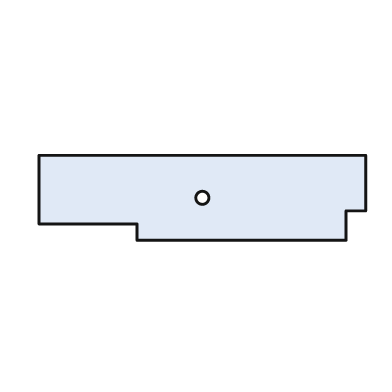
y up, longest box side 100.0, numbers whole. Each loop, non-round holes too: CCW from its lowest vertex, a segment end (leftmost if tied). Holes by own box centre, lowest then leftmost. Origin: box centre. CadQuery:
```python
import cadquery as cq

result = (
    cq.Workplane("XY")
    .moveTo(-20.0, -13.0)
    .lineTo(44.0, -13.0)
    .lineTo(44.0, -4.0)
    .lineTo(50.0, -4.0)
    .lineTo(50.0, 13.0)
    .lineTo(-50.0, 13.0)
    .lineTo(-50.0, -8.0)
    .lineTo(-20.0, -8.0)
    .close()
    .moveTo(0.0, 0.0)
    .circle(2.0)
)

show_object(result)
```